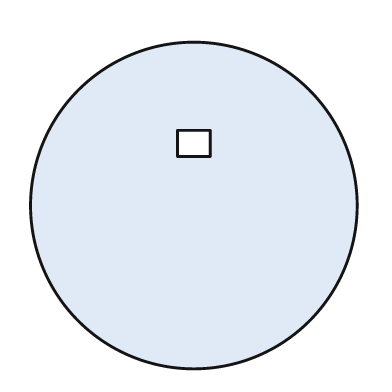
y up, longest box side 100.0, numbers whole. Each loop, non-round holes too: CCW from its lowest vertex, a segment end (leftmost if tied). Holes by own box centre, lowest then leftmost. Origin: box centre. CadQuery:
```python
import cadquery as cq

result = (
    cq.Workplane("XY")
    .moveTo(0.0, 0.0)
    .circle(50.0)
    .moveTo(-5.0, 15.0)
    .lineTo(5.0, 15.0)
    .lineTo(5.0, 23.0)
    .lineTo(-5.0, 23.0)
    .close()
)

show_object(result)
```